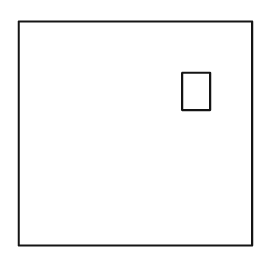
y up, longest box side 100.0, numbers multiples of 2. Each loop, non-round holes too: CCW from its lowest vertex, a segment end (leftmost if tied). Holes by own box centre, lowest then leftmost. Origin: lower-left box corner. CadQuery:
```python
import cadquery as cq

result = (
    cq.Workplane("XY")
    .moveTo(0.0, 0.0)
    .lineTo(100.0, 0.0)
    .lineTo(100.0, 96.0)
    .lineTo(0.0, 96.0)
    .close()
    .moveTo(70.0, 58.0)
    .lineTo(82.0, 58.0)
    .lineTo(82.0, 74.0)
    .lineTo(70.0, 74.0)
    .close()
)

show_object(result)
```